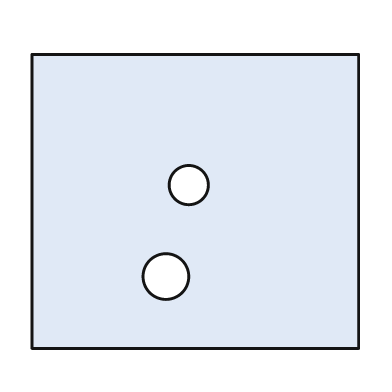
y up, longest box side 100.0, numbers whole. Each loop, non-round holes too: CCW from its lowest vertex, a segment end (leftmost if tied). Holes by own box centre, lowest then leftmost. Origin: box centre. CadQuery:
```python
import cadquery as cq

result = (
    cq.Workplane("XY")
    .moveTo(-50.0, -45.0)
    .lineTo(50.0, -45.0)
    .lineTo(50.0, 45.0)
    .lineTo(-50.0, 45.0)
    .close()
    .moveTo(-9.0, -23.0)
    .circle(7.0)
    .moveTo(-2.0, 5.0)
    .circle(6.0)
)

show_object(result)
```